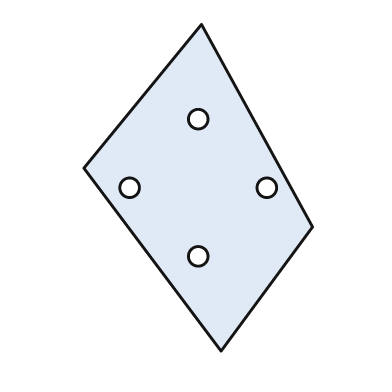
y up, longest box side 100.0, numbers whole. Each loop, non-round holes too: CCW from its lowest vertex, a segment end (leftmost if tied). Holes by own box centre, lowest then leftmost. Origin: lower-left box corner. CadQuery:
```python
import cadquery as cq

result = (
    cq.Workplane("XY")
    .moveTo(42.0, 0.0)
    .lineTo(70.0, 38.0)
    .lineTo(36.0, 100.0)
    .lineTo(0.0, 56.0)
    .close()
    .moveTo(35.0, 29.0)
    .circle(3.0)
    .moveTo(14.0, 50.0)
    .circle(3.0)
    .moveTo(56.0, 50.0)
    .circle(3.0)
    .moveTo(35.0, 71.0)
    .circle(3.0)
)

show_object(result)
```